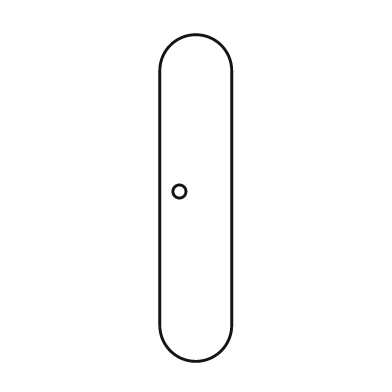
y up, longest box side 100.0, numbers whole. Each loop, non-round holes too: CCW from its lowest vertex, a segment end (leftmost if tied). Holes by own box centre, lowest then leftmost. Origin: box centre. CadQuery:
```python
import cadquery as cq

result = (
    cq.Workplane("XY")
    .moveTo(-11.0, -39.0)
    .threePointArc((0.0, -50.0), (11.0, -39.0))
    .lineTo(11.0, 39.0)
    .threePointArc((0.0, 50.0), (-11.0, 39.0))
    .close()
    .moveTo(-5.0, 2.0)
    .circle(2.0)
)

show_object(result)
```